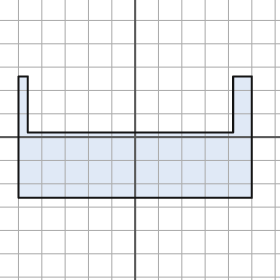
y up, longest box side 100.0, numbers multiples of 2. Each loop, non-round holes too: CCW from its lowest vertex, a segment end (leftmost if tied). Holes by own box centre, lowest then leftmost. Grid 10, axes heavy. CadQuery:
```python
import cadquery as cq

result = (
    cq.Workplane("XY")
    .moveTo(-50.0, -26.0)
    .lineTo(50.0, -26.0)
    .lineTo(50.0, 26.0)
    .lineTo(42.0, 26.0)
    .lineTo(42.0, 2.0)
    .lineTo(-46.0, 2.0)
    .lineTo(-46.0, 26.0)
    .lineTo(-50.0, 26.0)
    .close()
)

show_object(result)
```